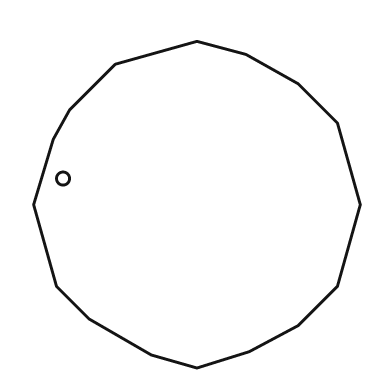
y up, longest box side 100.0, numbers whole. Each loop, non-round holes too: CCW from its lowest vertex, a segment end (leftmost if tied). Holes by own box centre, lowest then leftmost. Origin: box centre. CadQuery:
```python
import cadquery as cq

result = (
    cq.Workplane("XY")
    .moveTo(0.0, -50.0)
    .lineTo(16.0, -45.0)
    .lineTo(31.0, -37.0)
    .lineTo(43.0, -25.0)
    .lineTo(50.0, 0.0)
    .lineTo(43.0, 25.0)
    .lineTo(31.0, 37.0)
    .lineTo(15.0, 46.0)
    .lineTo(0.0, 50.0)
    .lineTo(-25.0, 43.0)
    .lineTo(-39.0, 29.0)
    .lineTo(-44.0, 20.0)
    .lineTo(-50.0, 0.0)
    .lineTo(-43.0, -25.0)
    .lineTo(-33.0, -35.0)
    .lineTo(-14.0, -46.0)
    .close()
    .moveTo(-41.0, 8.0)
    .circle(2.0)
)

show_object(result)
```